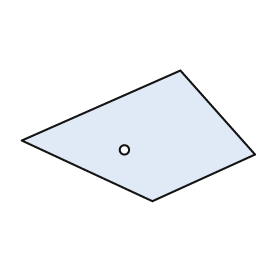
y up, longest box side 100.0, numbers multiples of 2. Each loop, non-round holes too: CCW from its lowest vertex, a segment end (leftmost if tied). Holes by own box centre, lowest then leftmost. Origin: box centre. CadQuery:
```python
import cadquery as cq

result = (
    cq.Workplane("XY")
    .moveTo(6.0, -28.0)
    .lineTo(50.0, -8.0)
    .lineTo(18.0, 28.0)
    .lineTo(-50.0, -2.0)
    .close()
    .moveTo(-6.0, -6.0)
    .circle(2.0)
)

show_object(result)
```